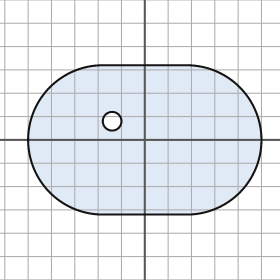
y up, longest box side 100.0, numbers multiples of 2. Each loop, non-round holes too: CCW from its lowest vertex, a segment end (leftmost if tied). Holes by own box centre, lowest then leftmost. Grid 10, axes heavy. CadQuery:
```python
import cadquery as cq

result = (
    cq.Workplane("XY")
    .moveTo(-18.0, -32.0)
    .lineTo(18.0, -32.0)
    .threePointArc((50.0, 0.0), (18.0, 32.0))
    .lineTo(-18.0, 32.0)
    .threePointArc((-50.0, 0.0), (-18.0, -32.0))
    .close()
    .moveTo(-14.0, 8.0)
    .circle(4.0)
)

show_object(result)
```